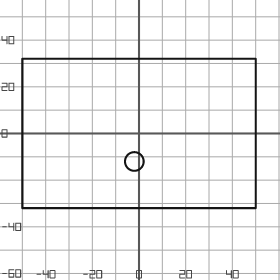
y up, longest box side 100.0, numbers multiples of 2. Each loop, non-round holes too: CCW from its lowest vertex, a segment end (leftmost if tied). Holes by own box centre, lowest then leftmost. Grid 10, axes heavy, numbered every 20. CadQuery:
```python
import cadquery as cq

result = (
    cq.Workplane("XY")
    .moveTo(-50.0, -32.0)
    .lineTo(50.0, -32.0)
    .lineTo(50.0, 32.0)
    .lineTo(-50.0, 32.0)
    .close()
    .moveTo(-2.0, -12.0)
    .circle(4.0)
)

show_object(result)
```